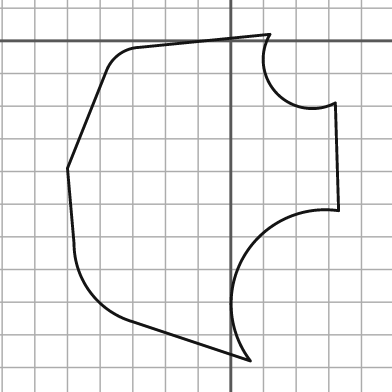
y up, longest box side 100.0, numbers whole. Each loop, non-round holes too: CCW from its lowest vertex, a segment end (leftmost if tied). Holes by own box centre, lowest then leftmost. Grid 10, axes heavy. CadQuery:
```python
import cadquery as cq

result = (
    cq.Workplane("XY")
    .moveTo(6.0, -98.0)
    .threePointArc((4.0, -66.0), (33.0, -52.0))
    .lineTo(32.0, -19.0)
    .threePointArc((14.0, -16.0), (12.0, 2.0))
    .lineTo(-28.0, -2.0)
    .threePointArc((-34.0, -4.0), (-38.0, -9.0))
    .lineTo(-50.0, -39.0)
    .lineTo(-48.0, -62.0)
    .threePointArc((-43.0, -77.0), (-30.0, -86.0))
    .close()
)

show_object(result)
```